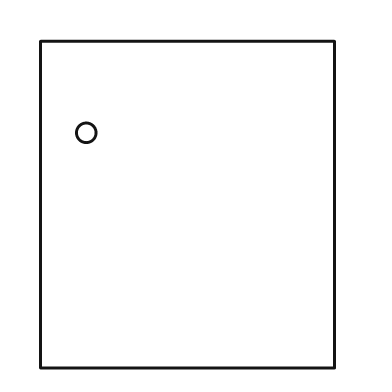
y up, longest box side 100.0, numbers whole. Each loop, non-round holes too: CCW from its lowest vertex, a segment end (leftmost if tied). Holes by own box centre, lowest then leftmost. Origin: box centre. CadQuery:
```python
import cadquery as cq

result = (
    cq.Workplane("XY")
    .moveTo(-45.0, -50.0)
    .lineTo(45.0, -50.0)
    .lineTo(45.0, 50.0)
    .lineTo(-45.0, 50.0)
    .close()
    .moveTo(-31.0, 22.0)
    .circle(3.0)
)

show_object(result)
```